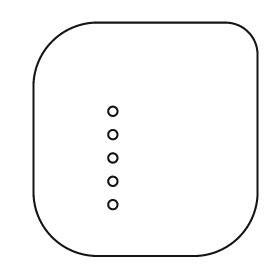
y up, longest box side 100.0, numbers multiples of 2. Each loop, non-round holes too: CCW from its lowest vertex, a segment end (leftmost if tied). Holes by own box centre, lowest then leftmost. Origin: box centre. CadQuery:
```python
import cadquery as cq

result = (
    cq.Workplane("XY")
    .moveTo(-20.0, -50.0)
    .lineTo(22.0, -50.0)
    .threePointArc((40.0, -42.0), (48.0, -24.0))
    .lineTo(48.0, 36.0)
    .threePointArc((44.0, 46.0), (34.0, 50.0))
    .lineTo(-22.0, 50.0)
    .threePointArc((-40.0, 42.0), (-48.0, 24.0))
    .lineTo(-48.0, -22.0)
    .threePointArc((-40.0, -42.0), (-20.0, -50.0))
    .close()
    .moveTo(-14.0, -28.0)
    .circle(2.0)
    .moveTo(-14.0, -18.0)
    .circle(2.0)
    .moveTo(-14.0, -8.0)
    .circle(2.0)
    .moveTo(-14.0, 2.0)
    .circle(2.0)
    .moveTo(-14.0, 12.0)
    .circle(2.0)
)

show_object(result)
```